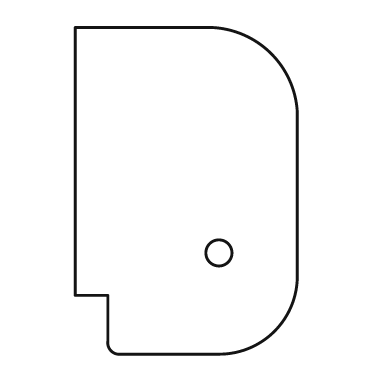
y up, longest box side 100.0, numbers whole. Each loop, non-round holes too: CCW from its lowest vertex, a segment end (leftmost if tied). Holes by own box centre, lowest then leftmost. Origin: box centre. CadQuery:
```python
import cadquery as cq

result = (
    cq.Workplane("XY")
    .moveTo(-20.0, -50.0)
    .lineTo(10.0, -50.0)
    .threePointArc((27.0, -43.0), (34.0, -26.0))
    .lineTo(34.0, 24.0)
    .threePointArc((26.0, 42.0), (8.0, 50.0))
    .lineTo(-34.0, 50.0)
    .lineTo(-34.0, -32.0)
    .lineTo(-24.0, -32.0)
    .lineTo(-24.0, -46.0)
    .threePointArc((-23.0, -49.0), (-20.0, -50.0))
    .close()
    .moveTo(10.0, -19.0)
    .circle(4.0)
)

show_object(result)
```